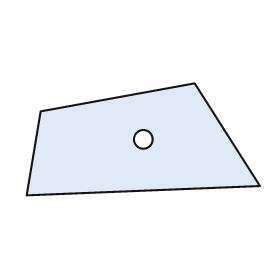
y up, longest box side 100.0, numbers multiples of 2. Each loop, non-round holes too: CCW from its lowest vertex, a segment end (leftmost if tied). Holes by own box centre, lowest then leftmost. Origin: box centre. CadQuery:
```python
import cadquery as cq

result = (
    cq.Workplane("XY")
    .moveTo(-50.0, -24.0)
    .lineTo(50.0, -20.0)
    .lineTo(22.0, 24.0)
    .lineTo(-44.0, 12.0)
    .close()
    .moveTo(0.0, 0.0)
    .circle(4.0)
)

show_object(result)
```